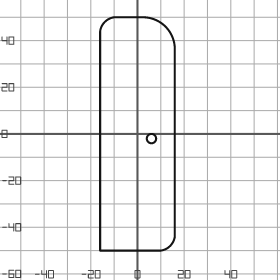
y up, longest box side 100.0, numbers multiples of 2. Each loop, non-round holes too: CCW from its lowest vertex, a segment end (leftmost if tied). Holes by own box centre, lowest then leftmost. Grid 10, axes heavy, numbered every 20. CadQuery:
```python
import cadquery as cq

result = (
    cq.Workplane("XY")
    .moveTo(-16.0, -50.0)
    .lineTo(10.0, -50.0)
    .threePointArc((14.0, -48.0), (16.0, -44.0))
    .lineTo(16.0, 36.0)
    .threePointArc((12.0, 46.0), (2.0, 50.0))
    .lineTo(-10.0, 50.0)
    .threePointArc((-14.0, 48.0), (-16.0, 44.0))
    .close()
    .moveTo(6.0, -2.0)
    .circle(2.0)
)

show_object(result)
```